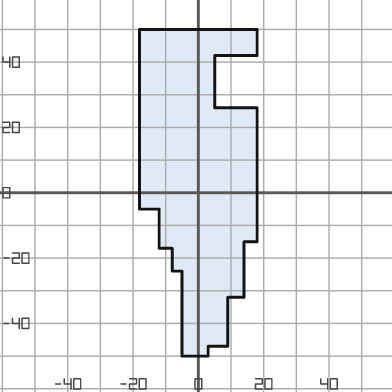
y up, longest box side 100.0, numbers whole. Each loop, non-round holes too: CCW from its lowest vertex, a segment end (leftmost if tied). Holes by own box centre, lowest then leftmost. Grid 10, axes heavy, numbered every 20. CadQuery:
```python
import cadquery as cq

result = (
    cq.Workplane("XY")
    .moveTo(-5.0, -50.0)
    .lineTo(3.0, -50.0)
    .lineTo(3.0, -47.0)
    .lineTo(9.0, -47.0)
    .lineTo(9.0, -32.0)
    .lineTo(14.0, -32.0)
    .lineTo(14.0, -15.0)
    .lineTo(18.0, -15.0)
    .lineTo(18.0, 26.0)
    .lineTo(5.0, 26.0)
    .lineTo(5.0, 42.0)
    .lineTo(18.0, 42.0)
    .lineTo(18.0, 50.0)
    .lineTo(-18.0, 50.0)
    .lineTo(-18.0, -5.0)
    .lineTo(-12.0, -5.0)
    .lineTo(-12.0, -17.0)
    .lineTo(-8.0, -17.0)
    .lineTo(-8.0, -24.0)
    .lineTo(-5.0, -24.0)
    .close()
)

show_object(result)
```